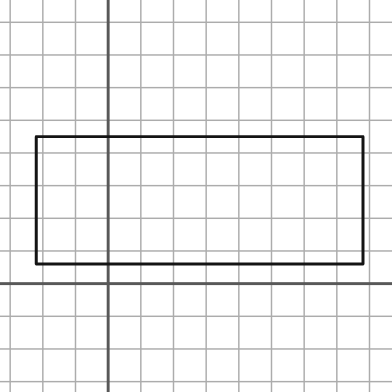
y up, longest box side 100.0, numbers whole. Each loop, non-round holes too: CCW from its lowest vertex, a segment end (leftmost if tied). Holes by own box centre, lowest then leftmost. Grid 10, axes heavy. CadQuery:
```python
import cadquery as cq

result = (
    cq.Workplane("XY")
    .moveTo(-22.0, 6.0)
    .lineTo(78.0, 6.0)
    .lineTo(78.0, 45.0)
    .lineTo(-22.0, 45.0)
    .close()
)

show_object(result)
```